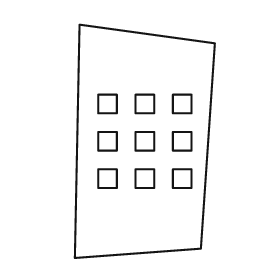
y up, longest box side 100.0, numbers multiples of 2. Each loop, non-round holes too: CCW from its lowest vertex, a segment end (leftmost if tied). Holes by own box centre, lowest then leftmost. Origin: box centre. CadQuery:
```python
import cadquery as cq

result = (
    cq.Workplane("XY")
    .moveTo(-30.0, -50.0)
    .lineTo(24.0, -46.0)
    .lineTo(30.0, 42.0)
    .lineTo(-28.0, 50.0)
    .close()
    .moveTo(-20.0, -20.0)
    .lineTo(-12.0, -20.0)
    .lineTo(-12.0, -12.0)
    .lineTo(-20.0, -12.0)
    .close()
    .moveTo(-4.0, -20.0)
    .lineTo(4.0, -20.0)
    .lineTo(4.0, -12.0)
    .lineTo(-4.0, -12.0)
    .close()
    .moveTo(12.0, -20.0)
    .lineTo(20.0, -20.0)
    .lineTo(20.0, -12.0)
    .lineTo(12.0, -12.0)
    .close()
    .moveTo(-20.0, -4.0)
    .lineTo(-12.0, -4.0)
    .lineTo(-12.0, 4.0)
    .lineTo(-20.0, 4.0)
    .close()
    .moveTo(-4.0, -4.0)
    .lineTo(4.0, -4.0)
    .lineTo(4.0, 4.0)
    .lineTo(-4.0, 4.0)
    .close()
    .moveTo(12.0, -4.0)
    .lineTo(20.0, -4.0)
    .lineTo(20.0, 4.0)
    .lineTo(12.0, 4.0)
    .close()
    .moveTo(-20.0, 12.0)
    .lineTo(-12.0, 12.0)
    .lineTo(-12.0, 20.0)
    .lineTo(-20.0, 20.0)
    .close()
    .moveTo(-4.0, 12.0)
    .lineTo(4.0, 12.0)
    .lineTo(4.0, 20.0)
    .lineTo(-4.0, 20.0)
    .close()
    .moveTo(12.0, 12.0)
    .lineTo(20.0, 12.0)
    .lineTo(20.0, 20.0)
    .lineTo(12.0, 20.0)
    .close()
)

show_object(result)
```